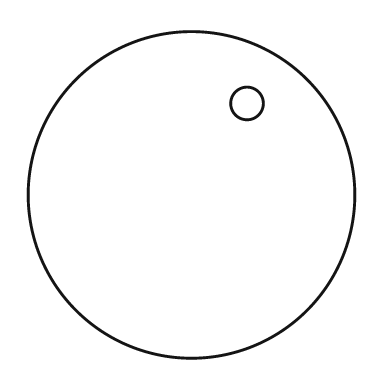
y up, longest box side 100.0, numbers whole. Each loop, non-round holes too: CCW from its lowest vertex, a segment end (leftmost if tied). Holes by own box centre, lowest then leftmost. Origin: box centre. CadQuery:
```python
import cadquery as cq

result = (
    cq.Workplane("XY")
    .moveTo(0.0, 0.0)
    .circle(50.0)
    .moveTo(17.0, 28.0)
    .circle(5.0)
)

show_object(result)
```